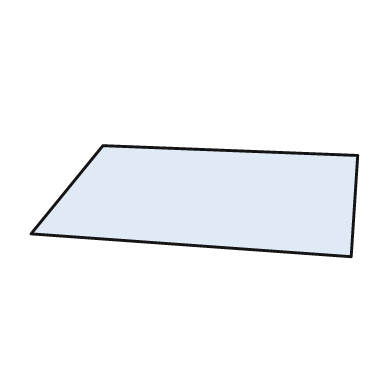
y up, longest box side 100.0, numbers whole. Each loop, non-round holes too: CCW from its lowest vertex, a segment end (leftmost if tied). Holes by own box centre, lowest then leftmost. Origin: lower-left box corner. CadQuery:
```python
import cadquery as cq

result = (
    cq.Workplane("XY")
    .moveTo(98.0, 0.0)
    .lineTo(100.0, 31.0)
    .lineTo(22.0, 34.0)
    .lineTo(0.0, 7.0)
    .close()
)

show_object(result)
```